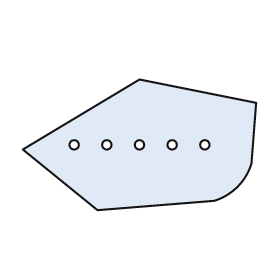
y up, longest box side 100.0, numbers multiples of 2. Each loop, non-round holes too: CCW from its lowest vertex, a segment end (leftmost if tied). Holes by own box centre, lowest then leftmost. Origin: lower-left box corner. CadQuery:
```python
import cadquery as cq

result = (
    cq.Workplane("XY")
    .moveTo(32.0, 0.0)
    .lineTo(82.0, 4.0)
    .threePointArc((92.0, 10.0), (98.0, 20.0))
    .lineTo(100.0, 46.0)
    .lineTo(50.0, 56.0)
    .lineTo(0.0, 26.0)
    .close()
    .moveTo(22.0, 28.0)
    .circle(2.0)
    .moveTo(36.0, 28.0)
    .circle(2.0)
    .moveTo(50.0, 28.0)
    .circle(2.0)
    .moveTo(64.0, 28.0)
    .circle(2.0)
    .moveTo(78.0, 28.0)
    .circle(2.0)
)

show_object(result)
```